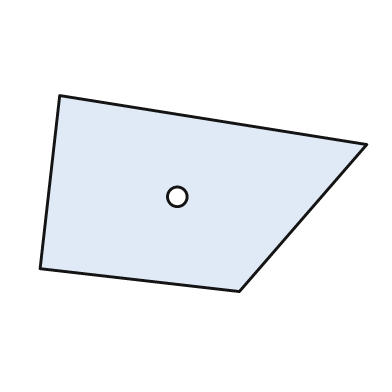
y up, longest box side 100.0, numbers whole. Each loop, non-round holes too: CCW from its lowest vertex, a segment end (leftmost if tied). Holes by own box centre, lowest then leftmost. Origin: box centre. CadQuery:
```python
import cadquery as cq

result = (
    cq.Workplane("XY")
    .moveTo(11.0, -30.0)
    .lineTo(50.0, 15.0)
    .lineTo(-44.0, 30.0)
    .lineTo(-50.0, -23.0)
    .close()
    .moveTo(-8.0, -1.0)
    .circle(3.0)
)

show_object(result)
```